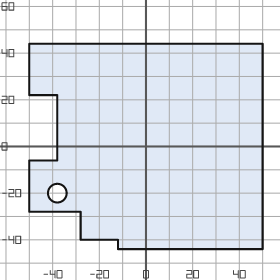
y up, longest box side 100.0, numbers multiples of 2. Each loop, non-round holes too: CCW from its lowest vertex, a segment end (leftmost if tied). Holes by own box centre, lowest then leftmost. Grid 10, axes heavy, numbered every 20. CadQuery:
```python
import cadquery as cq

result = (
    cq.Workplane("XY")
    .moveTo(-12.0, -44.0)
    .lineTo(50.0, -44.0)
    .lineTo(50.0, 44.0)
    .lineTo(-50.0, 44.0)
    .lineTo(-50.0, 22.0)
    .lineTo(-38.0, 22.0)
    .lineTo(-38.0, -6.0)
    .lineTo(-50.0, -6.0)
    .lineTo(-50.0, -28.0)
    .lineTo(-28.0, -28.0)
    .lineTo(-28.0, -40.0)
    .lineTo(-12.0, -40.0)
    .close()
    .moveTo(-38.0, -20.0)
    .circle(4.0)
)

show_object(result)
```